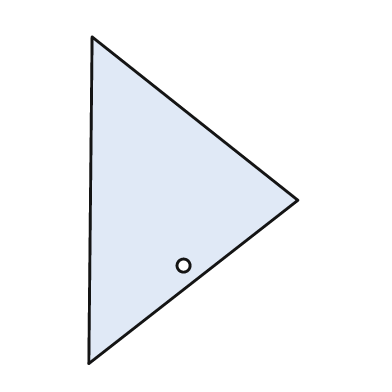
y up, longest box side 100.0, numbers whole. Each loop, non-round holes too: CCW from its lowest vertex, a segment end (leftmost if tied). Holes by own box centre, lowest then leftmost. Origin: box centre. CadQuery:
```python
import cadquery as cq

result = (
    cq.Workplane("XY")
    .moveTo(-32.0, -50.0)
    .lineTo(32.0, 0.0)
    .lineTo(-31.0, 50.0)
    .close()
    .moveTo(-3.0, -20.0)
    .circle(2.0)
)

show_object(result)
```